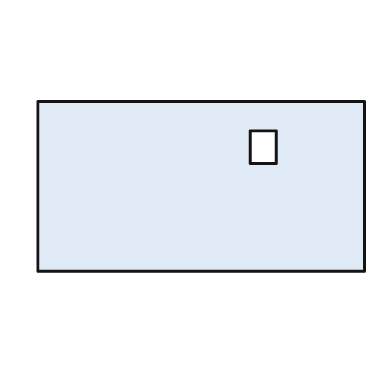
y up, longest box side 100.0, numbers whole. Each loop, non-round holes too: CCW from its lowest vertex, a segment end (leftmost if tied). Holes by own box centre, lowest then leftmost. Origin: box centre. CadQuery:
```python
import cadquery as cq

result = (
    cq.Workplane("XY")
    .moveTo(-50.0, -26.0)
    .lineTo(50.0, -26.0)
    .lineTo(50.0, 26.0)
    .lineTo(-50.0, 26.0)
    .close()
    .moveTo(15.0, 7.0)
    .lineTo(23.0, 7.0)
    .lineTo(23.0, 17.0)
    .lineTo(15.0, 17.0)
    .close()
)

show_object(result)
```